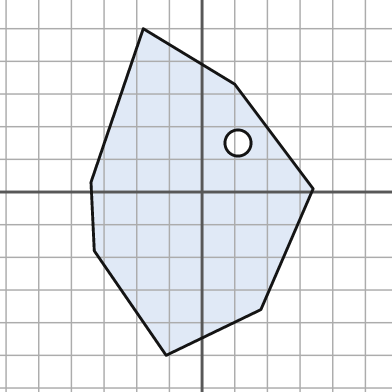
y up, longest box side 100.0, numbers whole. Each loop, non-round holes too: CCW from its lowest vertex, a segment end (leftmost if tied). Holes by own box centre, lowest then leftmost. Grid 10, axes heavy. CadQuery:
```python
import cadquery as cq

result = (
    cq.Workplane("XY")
    .moveTo(-11.0, -50.0)
    .lineTo(18.0, -36.0)
    .lineTo(34.0, 1.0)
    .lineTo(10.0, 33.0)
    .lineTo(-18.0, 50.0)
    .lineTo(-34.0, 3.0)
    .lineTo(-33.0, -18.0)
    .close()
    .moveTo(11.0, 15.0)
    .circle(4.0)
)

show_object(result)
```